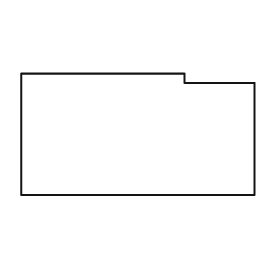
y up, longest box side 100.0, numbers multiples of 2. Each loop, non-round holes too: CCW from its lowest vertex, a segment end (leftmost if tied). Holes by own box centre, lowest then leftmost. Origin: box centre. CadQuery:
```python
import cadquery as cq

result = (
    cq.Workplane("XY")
    .moveTo(-50.0, -26.0)
    .lineTo(50.0, -26.0)
    .lineTo(50.0, 22.0)
    .lineTo(20.0, 22.0)
    .lineTo(20.0, 26.0)
    .lineTo(-50.0, 26.0)
    .close()
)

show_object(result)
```